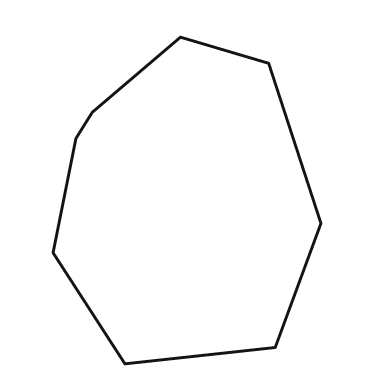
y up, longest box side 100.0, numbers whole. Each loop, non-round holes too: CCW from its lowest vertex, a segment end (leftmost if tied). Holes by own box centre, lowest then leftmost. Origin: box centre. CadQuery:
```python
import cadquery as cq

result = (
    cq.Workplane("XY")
    .moveTo(-19.0, -50.0)
    .lineTo(27.0, -45.0)
    .lineTo(41.0, -7.0)
    .lineTo(25.0, 42.0)
    .lineTo(-2.0, 50.0)
    .lineTo(-29.0, 27.0)
    .lineTo(-34.0, 19.0)
    .lineTo(-41.0, -16.0)
    .close()
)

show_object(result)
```